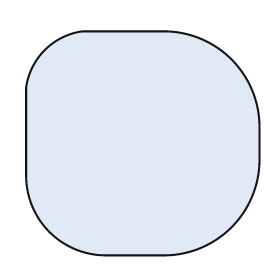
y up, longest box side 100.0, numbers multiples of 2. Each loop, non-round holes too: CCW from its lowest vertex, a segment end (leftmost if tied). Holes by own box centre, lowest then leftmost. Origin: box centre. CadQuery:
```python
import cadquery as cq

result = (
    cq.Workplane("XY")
    .moveTo(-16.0, -48.0)
    .lineTo(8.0, -48.0)
    .threePointArc((38.0, -36.0), (50.0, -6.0))
    .lineTo(50.0, 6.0)
    .threePointArc((38.0, 36.0), (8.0, 48.0))
    .lineTo(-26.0, 48.0)
    .threePointArc((-42.0, 40.0), (-50.0, 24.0))
    .lineTo(-50.0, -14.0)
    .threePointArc((-40.0, -38.0), (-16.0, -48.0))
    .close()
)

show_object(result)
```